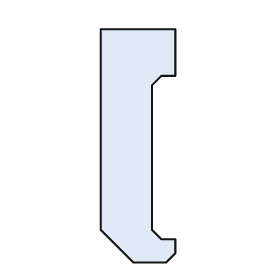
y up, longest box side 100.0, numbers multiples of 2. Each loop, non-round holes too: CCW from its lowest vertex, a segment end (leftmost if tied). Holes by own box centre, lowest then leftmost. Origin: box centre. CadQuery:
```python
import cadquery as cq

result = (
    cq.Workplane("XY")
    .moveTo(-2.0, -50.0)
    .lineTo(12.0, -50.0)
    .lineTo(16.0, -46.0)
    .lineTo(16.0, -40.0)
    .lineTo(10.0, -40.0)
    .lineTo(6.0, -36.0)
    .lineTo(6.0, 26.0)
    .lineTo(10.0, 30.0)
    .lineTo(16.0, 30.0)
    .lineTo(16.0, 50.0)
    .lineTo(-16.0, 50.0)
    .lineTo(-16.0, -36.0)
    .close()
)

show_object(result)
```